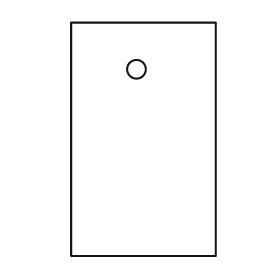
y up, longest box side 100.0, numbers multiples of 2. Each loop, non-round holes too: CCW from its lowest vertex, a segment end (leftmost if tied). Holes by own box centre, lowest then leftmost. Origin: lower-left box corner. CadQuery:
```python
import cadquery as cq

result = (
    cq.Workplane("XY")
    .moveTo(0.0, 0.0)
    .lineTo(62.0, 0.0)
    .lineTo(62.0, 100.0)
    .lineTo(0.0, 100.0)
    .close()
    .moveTo(28.0, 80.0)
    .circle(4.0)
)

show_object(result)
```